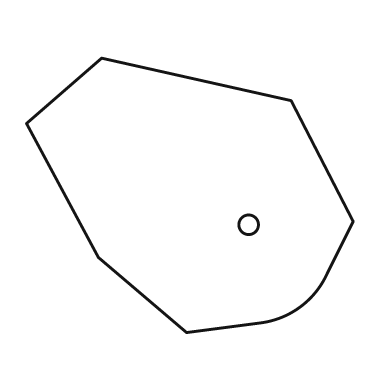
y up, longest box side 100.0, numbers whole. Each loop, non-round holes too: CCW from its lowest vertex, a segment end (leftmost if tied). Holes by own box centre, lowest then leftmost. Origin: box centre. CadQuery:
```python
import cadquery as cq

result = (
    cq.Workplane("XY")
    .moveTo(-1.0, -42.0)
    .lineTo(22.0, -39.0)
    .threePointArc((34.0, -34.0), (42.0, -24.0))
    .lineTo(50.0, -8.0)
    .lineTo(31.0, 29.0)
    .lineTo(-27.0, 42.0)
    .lineTo(-50.0, 22.0)
    .lineTo(-28.0, -19.0)
    .close()
    .moveTo(18.0, -9.0)
    .circle(3.0)
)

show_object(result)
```